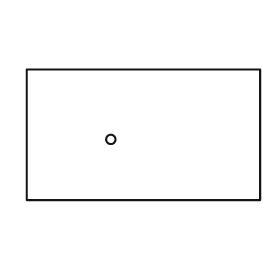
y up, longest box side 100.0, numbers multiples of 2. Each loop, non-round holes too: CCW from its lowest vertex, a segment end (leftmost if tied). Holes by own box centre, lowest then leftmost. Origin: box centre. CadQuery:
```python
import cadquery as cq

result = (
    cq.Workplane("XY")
    .moveTo(-50.0, -28.0)
    .lineTo(50.0, -28.0)
    .lineTo(50.0, 28.0)
    .lineTo(-50.0, 28.0)
    .close()
    .moveTo(-14.0, -2.0)
    .circle(2.0)
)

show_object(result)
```